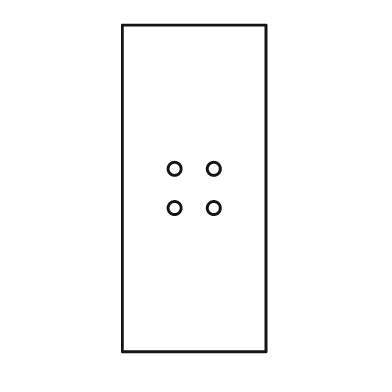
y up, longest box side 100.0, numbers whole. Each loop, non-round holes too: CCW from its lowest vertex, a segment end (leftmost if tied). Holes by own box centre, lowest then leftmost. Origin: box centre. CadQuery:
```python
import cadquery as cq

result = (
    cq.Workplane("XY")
    .moveTo(-22.0, -50.0)
    .lineTo(22.0, -50.0)
    .lineTo(22.0, 50.0)
    .lineTo(-22.0, 50.0)
    .close()
    .moveTo(-6.0, -6.0)
    .circle(2.0)
    .moveTo(6.0, -6.0)
    .circle(2.0)
    .moveTo(-6.0, 6.0)
    .circle(2.0)
    .moveTo(6.0, 6.0)
    .circle(2.0)
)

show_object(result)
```